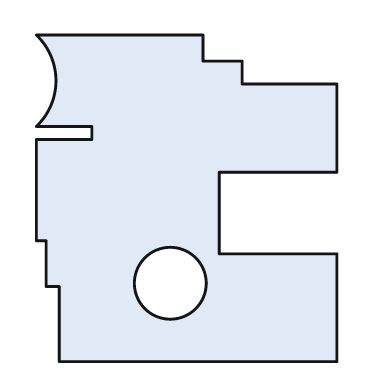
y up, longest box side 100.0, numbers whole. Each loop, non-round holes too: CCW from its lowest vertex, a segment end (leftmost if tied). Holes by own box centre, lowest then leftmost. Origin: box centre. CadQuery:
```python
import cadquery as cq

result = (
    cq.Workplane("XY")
    .moveTo(-39.0, -50.0)
    .lineTo(46.0, -50.0)
    .lineTo(46.0, -17.0)
    .lineTo(10.0, -17.0)
    .lineTo(10.0, 8.0)
    .lineTo(46.0, 8.0)
    .lineTo(46.0, 35.0)
    .lineTo(17.0, 35.0)
    .lineTo(17.0, 42.0)
    .lineTo(5.0, 42.0)
    .lineTo(5.0, 50.0)
    .lineTo(-46.0, 50.0)
    .threePointArc((-40.0, 36.0), (-46.0, 22.0))
    .lineTo(-29.0, 22.0)
    .lineTo(-29.0, 18.0)
    .lineTo(-46.0, 18.0)
    .lineTo(-46.0, -13.0)
    .lineTo(-43.0, -13.0)
    .lineTo(-43.0, -27.0)
    .lineTo(-39.0, -27.0)
    .close()
    .moveTo(-5.0, -26.0)
    .circle(11.0)
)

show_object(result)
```